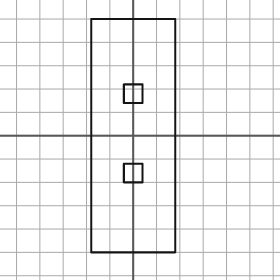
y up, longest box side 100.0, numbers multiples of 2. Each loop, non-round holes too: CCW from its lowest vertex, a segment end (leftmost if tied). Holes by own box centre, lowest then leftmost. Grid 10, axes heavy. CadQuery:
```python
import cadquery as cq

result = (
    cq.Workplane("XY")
    .moveTo(-18.0, -50.0)
    .lineTo(18.0, -50.0)
    .lineTo(18.0, 50.0)
    .lineTo(-18.0, 50.0)
    .close()
    .moveTo(-4.0, -20.0)
    .lineTo(4.0, -20.0)
    .lineTo(4.0, -12.0)
    .lineTo(-4.0, -12.0)
    .close()
    .moveTo(-4.0, 14.0)
    .lineTo(4.0, 14.0)
    .lineTo(4.0, 22.0)
    .lineTo(-4.0, 22.0)
    .close()
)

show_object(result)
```